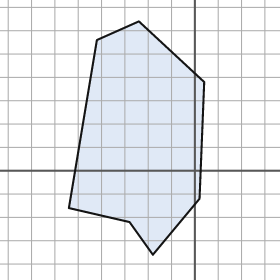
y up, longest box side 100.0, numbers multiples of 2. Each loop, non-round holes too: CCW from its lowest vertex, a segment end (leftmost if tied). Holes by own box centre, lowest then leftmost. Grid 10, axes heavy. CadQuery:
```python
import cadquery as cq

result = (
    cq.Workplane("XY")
    .moveTo(-18.0, -36.0)
    .lineTo(2.0, -12.0)
    .lineTo(4.0, 38.0)
    .lineTo(-24.0, 64.0)
    .lineTo(-42.0, 56.0)
    .lineTo(-54.0, -16.0)
    .lineTo(-28.0, -22.0)
    .close()
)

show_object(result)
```